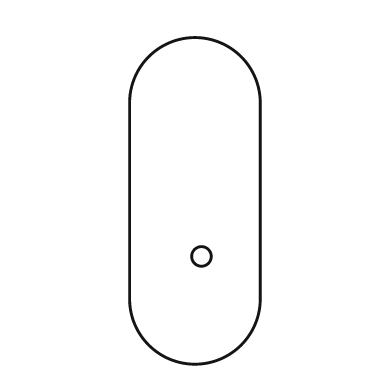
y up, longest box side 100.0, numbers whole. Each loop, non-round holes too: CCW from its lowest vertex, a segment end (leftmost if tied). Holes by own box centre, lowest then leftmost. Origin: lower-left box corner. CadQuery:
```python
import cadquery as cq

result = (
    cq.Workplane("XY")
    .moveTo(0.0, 20.0)
    .threePointArc((20.0, 0.0), (40.0, 20.0))
    .lineTo(40.0, 80.0)
    .threePointArc((20.0, 100.0), (0.0, 80.0))
    .close()
    .moveTo(22.0, 33.0)
    .circle(3.0)
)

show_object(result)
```